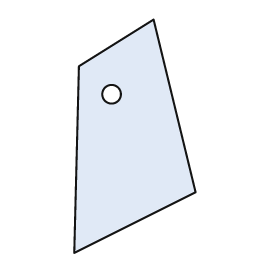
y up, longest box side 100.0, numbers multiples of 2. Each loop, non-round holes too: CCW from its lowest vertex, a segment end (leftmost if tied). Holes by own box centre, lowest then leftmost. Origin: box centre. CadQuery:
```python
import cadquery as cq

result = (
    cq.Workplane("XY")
    .moveTo(-26.0, -50.0)
    .lineTo(26.0, -24.0)
    .lineTo(8.0, 50.0)
    .lineTo(-24.0, 30.0)
    .close()
    .moveTo(-10.0, 18.0)
    .circle(4.0)
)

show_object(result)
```